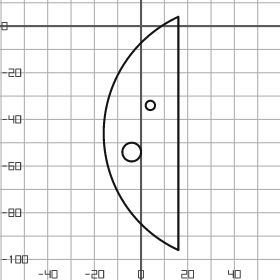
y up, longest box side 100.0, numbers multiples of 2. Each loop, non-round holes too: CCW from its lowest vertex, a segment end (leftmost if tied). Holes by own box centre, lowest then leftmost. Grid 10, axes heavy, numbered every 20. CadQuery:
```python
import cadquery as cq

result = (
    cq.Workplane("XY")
    .moveTo(16.0, -96.0)
    .lineTo(16.0, 4.0)
    .threePointArc((-16.0, -46.0), (16.0, -96.0))
    .close()
    .moveTo(-4.0, -54.0)
    .circle(4.0)
    .moveTo(4.0, -34.0)
    .circle(2.0)
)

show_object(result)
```